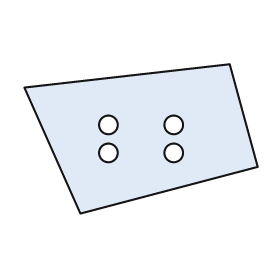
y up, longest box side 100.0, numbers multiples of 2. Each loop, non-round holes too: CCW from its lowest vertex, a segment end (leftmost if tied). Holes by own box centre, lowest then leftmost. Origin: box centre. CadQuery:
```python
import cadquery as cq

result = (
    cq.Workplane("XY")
    .moveTo(-26.0, -32.0)
    .lineTo(50.0, -12.0)
    .lineTo(38.0, 32.0)
    .lineTo(-50.0, 22.0)
    .close()
    .moveTo(-14.0, -6.0)
    .circle(4.0)
    .moveTo(14.0, -6.0)
    .circle(4.0)
    .moveTo(-14.0, 6.0)
    .circle(4.0)
    .moveTo(14.0, 6.0)
    .circle(4.0)
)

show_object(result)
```